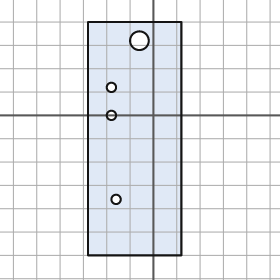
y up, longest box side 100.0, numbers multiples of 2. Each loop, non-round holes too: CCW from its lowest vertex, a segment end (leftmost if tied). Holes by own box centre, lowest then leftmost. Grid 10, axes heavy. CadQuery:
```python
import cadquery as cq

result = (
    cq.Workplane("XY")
    .moveTo(-28.0, -60.0)
    .lineTo(12.0, -60.0)
    .lineTo(12.0, 40.0)
    .lineTo(-28.0, 40.0)
    .close()
    .moveTo(-16.0, -36.0)
    .circle(2.0)
    .moveTo(-18.0, 0.0)
    .circle(2.0)
    .moveTo(-18.0, 12.0)
    .circle(2.0)
    .moveTo(-6.0, 32.0)
    .circle(4.0)
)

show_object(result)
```